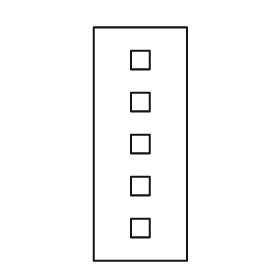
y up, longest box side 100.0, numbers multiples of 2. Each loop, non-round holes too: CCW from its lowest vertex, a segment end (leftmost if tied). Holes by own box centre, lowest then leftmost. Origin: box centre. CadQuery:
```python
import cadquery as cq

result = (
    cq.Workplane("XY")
    .moveTo(-20.0, -50.0)
    .lineTo(20.0, -50.0)
    .lineTo(20.0, 50.0)
    .lineTo(-20.0, 50.0)
    .close()
    .moveTo(-4.0, -40.0)
    .lineTo(4.0, -40.0)
    .lineTo(4.0, -32.0)
    .lineTo(-4.0, -32.0)
    .close()
    .moveTo(-4.0, -22.0)
    .lineTo(4.0, -22.0)
    .lineTo(4.0, -14.0)
    .lineTo(-4.0, -14.0)
    .close()
    .moveTo(-4.0, -4.0)
    .lineTo(4.0, -4.0)
    .lineTo(4.0, 4.0)
    .lineTo(-4.0, 4.0)
    .close()
    .moveTo(-4.0, 14.0)
    .lineTo(4.0, 14.0)
    .lineTo(4.0, 22.0)
    .lineTo(-4.0, 22.0)
    .close()
    .moveTo(-4.0, 32.0)
    .lineTo(4.0, 32.0)
    .lineTo(4.0, 40.0)
    .lineTo(-4.0, 40.0)
    .close()
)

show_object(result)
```